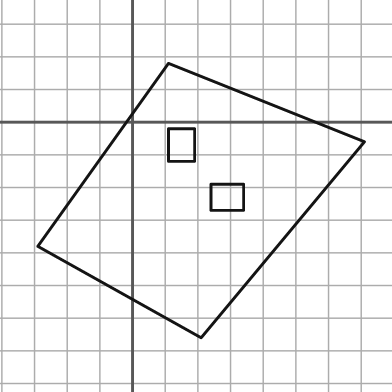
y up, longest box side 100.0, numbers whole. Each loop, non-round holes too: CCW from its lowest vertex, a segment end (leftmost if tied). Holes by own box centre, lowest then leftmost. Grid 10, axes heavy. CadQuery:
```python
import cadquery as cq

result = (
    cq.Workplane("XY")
    .moveTo(21.0, -66.0)
    .lineTo(71.0, -6.0)
    .lineTo(11.0, 18.0)
    .lineTo(-29.0, -38.0)
    .close()
    .moveTo(24.0, -27.0)
    .lineTo(34.0, -27.0)
    .lineTo(34.0, -19.0)
    .lineTo(24.0, -19.0)
    .close()
    .moveTo(11.0, -12.0)
    .lineTo(19.0, -12.0)
    .lineTo(19.0, -2.0)
    .lineTo(11.0, -2.0)
    .close()
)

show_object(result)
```